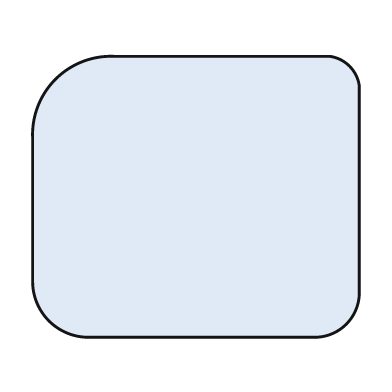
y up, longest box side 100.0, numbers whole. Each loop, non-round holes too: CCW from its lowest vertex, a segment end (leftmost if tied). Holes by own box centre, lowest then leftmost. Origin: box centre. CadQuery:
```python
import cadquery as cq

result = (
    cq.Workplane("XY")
    .moveTo(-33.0, -43.0)
    .lineTo(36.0, -43.0)
    .threePointArc((46.0, -39.0), (50.0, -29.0))
    .lineTo(50.0, 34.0)
    .threePointArc((47.0, 40.0), (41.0, 43.0))
    .lineTo(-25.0, 43.0)
    .threePointArc((-43.0, 36.0), (-50.0, 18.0))
    .lineTo(-50.0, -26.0)
    .threePointArc((-45.0, -38.0), (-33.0, -43.0))
    .close()
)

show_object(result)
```